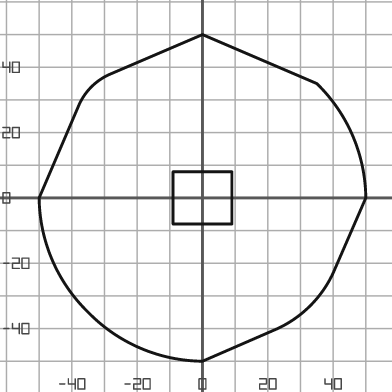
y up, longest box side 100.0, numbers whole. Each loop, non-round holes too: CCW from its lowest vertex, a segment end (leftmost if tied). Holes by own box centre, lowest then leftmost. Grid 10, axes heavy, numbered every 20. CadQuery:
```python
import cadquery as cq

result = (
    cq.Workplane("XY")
    .moveTo(0.0, -50.0)
    .lineTo(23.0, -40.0)
    .threePointArc((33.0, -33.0), (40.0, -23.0))
    .lineTo(50.0, 0.0)
    .threePointArc((46.0, 19.0), (35.0, 35.0))
    .lineTo(0.0, 50.0)
    .lineTo(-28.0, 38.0)
    .threePointArc((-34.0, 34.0), (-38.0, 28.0))
    .lineTo(-50.0, 0.0)
    .threePointArc((-46.0, -19.0), (-35.0, -35.0))
    .threePointArc((-19.0, -46.0), (0.0, -50.0))
    .close()
    .moveTo(-9.0, -8.0)
    .lineTo(9.0, -8.0)
    .lineTo(9.0, 8.0)
    .lineTo(-9.0, 8.0)
    .close()
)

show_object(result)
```